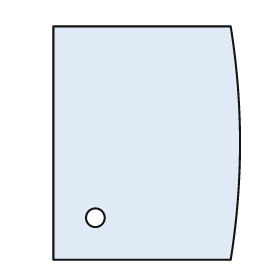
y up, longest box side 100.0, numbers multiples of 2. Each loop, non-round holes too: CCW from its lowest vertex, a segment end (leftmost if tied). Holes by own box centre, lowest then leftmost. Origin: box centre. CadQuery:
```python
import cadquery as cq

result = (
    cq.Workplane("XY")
    .moveTo(-40.0, -50.0)
    .lineTo(36.0, -50.0)
    .threePointArc((40.0, 0.0), (36.0, 50.0))
    .lineTo(-40.0, 50.0)
    .close()
    .moveTo(-22.0, -32.0)
    .circle(4.0)
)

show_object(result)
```